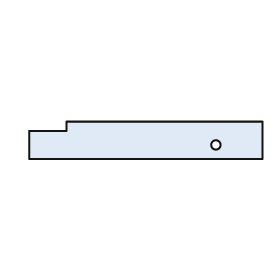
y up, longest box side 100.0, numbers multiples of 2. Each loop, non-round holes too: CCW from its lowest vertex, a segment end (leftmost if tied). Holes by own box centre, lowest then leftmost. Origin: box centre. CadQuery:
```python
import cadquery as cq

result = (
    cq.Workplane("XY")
    .moveTo(-50.0, -8.0)
    .lineTo(50.0, -8.0)
    .lineTo(50.0, 8.0)
    .lineTo(-34.0, 8.0)
    .lineTo(-34.0, 4.0)
    .lineTo(-50.0, 4.0)
    .close()
    .moveTo(30.0, -2.0)
    .circle(2.0)
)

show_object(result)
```